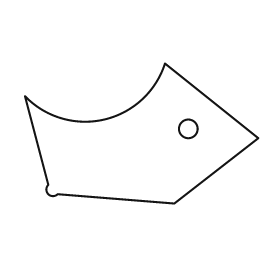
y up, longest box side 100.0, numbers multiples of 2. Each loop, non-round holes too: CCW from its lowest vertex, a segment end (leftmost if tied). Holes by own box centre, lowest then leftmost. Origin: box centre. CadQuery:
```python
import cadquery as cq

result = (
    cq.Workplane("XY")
    .moveTo(14.0, -30.0)
    .lineTo(50.0, -2.0)
    .lineTo(10.0, 30.0)
    .threePointArc((-16.0, 6.0), (-50.0, 16.0))
    .lineTo(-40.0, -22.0)
    .threePointArc((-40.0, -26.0), (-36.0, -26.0))
    .close()
    .moveTo(20.0, 2.0)
    .circle(4.0)
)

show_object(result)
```